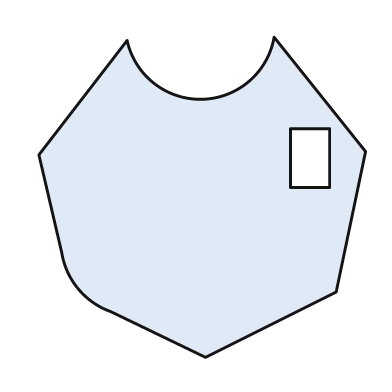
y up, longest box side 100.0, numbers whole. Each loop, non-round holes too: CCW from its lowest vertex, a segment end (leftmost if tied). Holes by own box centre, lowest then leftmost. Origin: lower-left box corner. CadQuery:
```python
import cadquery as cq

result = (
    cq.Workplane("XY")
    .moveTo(51.0, 0.0)
    .lineTo(91.0, 20.0)
    .lineTo(100.0, 63.0)
    .lineTo(72.0, 98.0)
    .threePointArc((50.0, 79.0), (27.0, 97.0))
    .lineTo(0.0, 62.0)
    .lineTo(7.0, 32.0)
    .threePointArc((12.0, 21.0), (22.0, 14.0))
    .close()
    .moveTo(77.0, 52.0)
    .lineTo(89.0, 52.0)
    .lineTo(89.0, 70.0)
    .lineTo(77.0, 70.0)
    .close()
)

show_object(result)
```